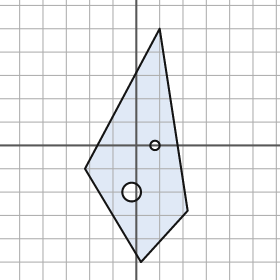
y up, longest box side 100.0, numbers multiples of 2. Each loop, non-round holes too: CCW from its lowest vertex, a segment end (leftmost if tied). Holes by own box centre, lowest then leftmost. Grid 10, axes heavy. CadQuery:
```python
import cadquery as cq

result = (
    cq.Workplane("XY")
    .moveTo(2.0, -50.0)
    .lineTo(22.0, -28.0)
    .lineTo(10.0, 50.0)
    .lineTo(-22.0, -10.0)
    .close()
    .moveTo(-2.0, -20.0)
    .circle(4.0)
    .moveTo(8.0, 0.0)
    .circle(2.0)
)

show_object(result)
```